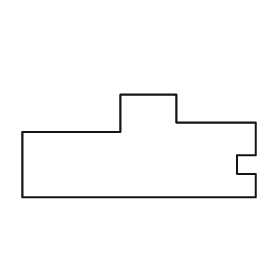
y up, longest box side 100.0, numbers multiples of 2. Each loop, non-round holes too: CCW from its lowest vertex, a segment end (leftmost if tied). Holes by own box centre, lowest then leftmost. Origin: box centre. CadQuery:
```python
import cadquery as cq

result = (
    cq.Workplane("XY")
    .moveTo(-50.0, -22.0)
    .lineTo(50.0, -22.0)
    .lineTo(50.0, -12.0)
    .lineTo(42.0, -12.0)
    .lineTo(42.0, -4.0)
    .lineTo(50.0, -4.0)
    .lineTo(50.0, 10.0)
    .lineTo(16.0, 10.0)
    .lineTo(16.0, 22.0)
    .lineTo(-8.0, 22.0)
    .lineTo(-8.0, 6.0)
    .lineTo(-50.0, 6.0)
    .close()
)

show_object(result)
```